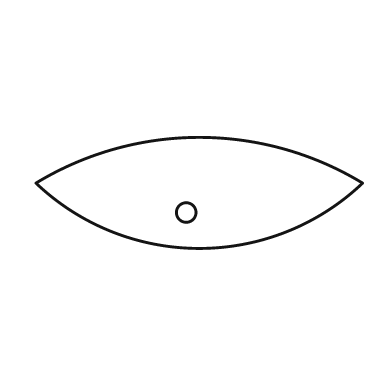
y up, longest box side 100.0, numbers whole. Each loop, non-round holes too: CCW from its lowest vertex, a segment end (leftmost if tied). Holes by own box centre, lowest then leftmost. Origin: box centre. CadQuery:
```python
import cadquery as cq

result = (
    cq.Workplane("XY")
    .moveTo(-50.0, 3.0)
    .threePointArc((0.0, -17.0), (50.0, 3.0))
    .threePointArc((0.0, 17.0), (-50.0, 3.0))
    .close()
    .moveTo(-4.0, -6.0)
    .circle(3.0)
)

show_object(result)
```